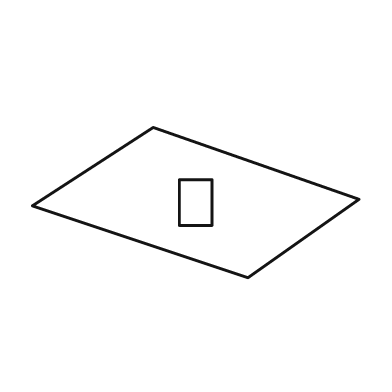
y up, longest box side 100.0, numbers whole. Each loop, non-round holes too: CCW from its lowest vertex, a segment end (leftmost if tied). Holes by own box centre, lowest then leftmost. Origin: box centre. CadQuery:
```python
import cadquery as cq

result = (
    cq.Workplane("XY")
    .moveTo(16.0, -23.0)
    .lineTo(50.0, 1.0)
    .lineTo(-13.0, 23.0)
    .lineTo(-50.0, -1.0)
    .close()
    .moveTo(-5.0, -7.0)
    .lineTo(5.0, -7.0)
    .lineTo(5.0, 7.0)
    .lineTo(-5.0, 7.0)
    .close()
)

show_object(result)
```